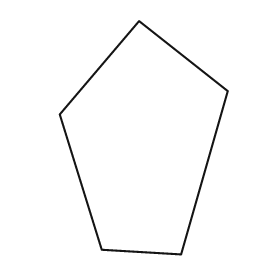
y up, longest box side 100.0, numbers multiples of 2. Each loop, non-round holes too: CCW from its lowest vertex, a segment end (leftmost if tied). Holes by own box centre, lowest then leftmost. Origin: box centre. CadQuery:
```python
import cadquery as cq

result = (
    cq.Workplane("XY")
    .moveTo(16.0, -50.0)
    .lineTo(36.0, 20.0)
    .lineTo(-2.0, 50.0)
    .lineTo(-36.0, 10.0)
    .lineTo(-18.0, -48.0)
    .close()
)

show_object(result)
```